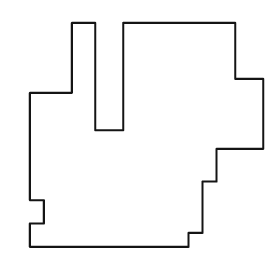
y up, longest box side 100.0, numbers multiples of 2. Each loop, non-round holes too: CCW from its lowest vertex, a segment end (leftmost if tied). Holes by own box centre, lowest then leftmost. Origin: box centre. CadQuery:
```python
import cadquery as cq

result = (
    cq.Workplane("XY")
    .moveTo(-50.0, -48.0)
    .lineTo(18.0, -48.0)
    .lineTo(18.0, -42.0)
    .lineTo(24.0, -42.0)
    .lineTo(24.0, -20.0)
    .lineTo(30.0, -20.0)
    .lineTo(30.0, -6.0)
    .lineTo(50.0, -6.0)
    .lineTo(50.0, 24.0)
    .lineTo(38.0, 24.0)
    .lineTo(38.0, 48.0)
    .lineTo(-10.0, 48.0)
    .lineTo(-10.0, 2.0)
    .lineTo(-22.0, 2.0)
    .lineTo(-22.0, 48.0)
    .lineTo(-32.0, 48.0)
    .lineTo(-32.0, 18.0)
    .lineTo(-50.0, 18.0)
    .lineTo(-50.0, -28.0)
    .lineTo(-44.0, -28.0)
    .lineTo(-44.0, -38.0)
    .lineTo(-50.0, -38.0)
    .close()
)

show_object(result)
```